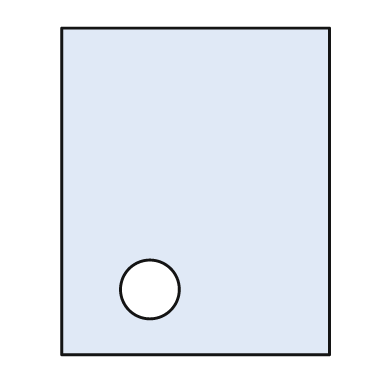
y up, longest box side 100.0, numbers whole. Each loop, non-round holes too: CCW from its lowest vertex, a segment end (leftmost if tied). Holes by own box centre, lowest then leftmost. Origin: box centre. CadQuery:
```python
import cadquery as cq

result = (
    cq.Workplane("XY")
    .moveTo(-41.0, -50.0)
    .lineTo(41.0, -50.0)
    .lineTo(41.0, 50.0)
    .lineTo(-41.0, 50.0)
    .close()
    .moveTo(-14.0, -30.0)
    .circle(9.0)
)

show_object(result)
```